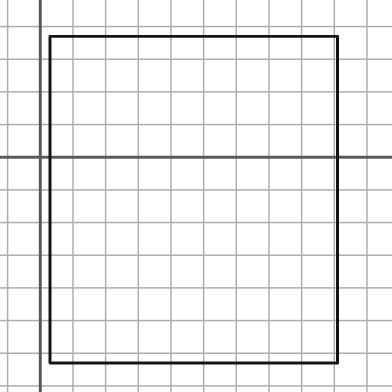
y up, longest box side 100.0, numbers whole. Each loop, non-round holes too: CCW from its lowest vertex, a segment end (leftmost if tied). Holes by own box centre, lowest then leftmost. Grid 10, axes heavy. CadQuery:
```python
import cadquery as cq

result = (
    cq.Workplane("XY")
    .moveTo(3.0, -63.0)
    .lineTo(91.0, -63.0)
    .lineTo(91.0, 37.0)
    .lineTo(3.0, 37.0)
    .close()
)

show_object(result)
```